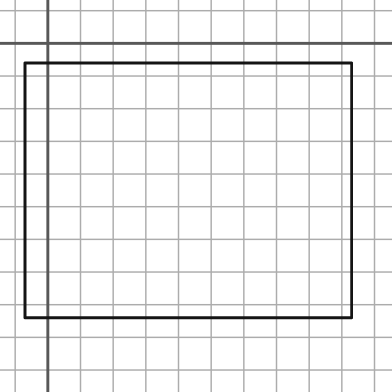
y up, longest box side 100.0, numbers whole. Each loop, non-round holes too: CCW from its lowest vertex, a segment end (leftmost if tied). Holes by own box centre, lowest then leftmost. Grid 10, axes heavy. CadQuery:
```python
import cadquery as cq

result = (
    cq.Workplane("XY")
    .moveTo(-7.0, -84.0)
    .lineTo(93.0, -84.0)
    .lineTo(93.0, -6.0)
    .lineTo(-7.0, -6.0)
    .close()
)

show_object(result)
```